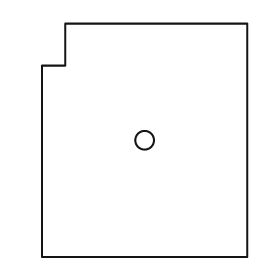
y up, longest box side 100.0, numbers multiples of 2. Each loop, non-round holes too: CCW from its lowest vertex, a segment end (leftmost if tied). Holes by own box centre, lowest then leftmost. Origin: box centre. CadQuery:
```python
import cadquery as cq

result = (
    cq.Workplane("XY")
    .moveTo(-44.0, -50.0)
    .lineTo(44.0, -50.0)
    .lineTo(44.0, 50.0)
    .lineTo(-34.0, 50.0)
    .lineTo(-34.0, 32.0)
    .lineTo(-44.0, 32.0)
    .close()
    .moveTo(0.0, 0.0)
    .circle(4.0)
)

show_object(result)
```